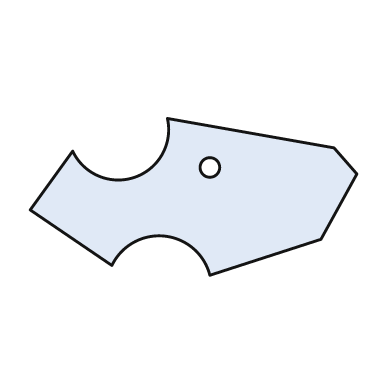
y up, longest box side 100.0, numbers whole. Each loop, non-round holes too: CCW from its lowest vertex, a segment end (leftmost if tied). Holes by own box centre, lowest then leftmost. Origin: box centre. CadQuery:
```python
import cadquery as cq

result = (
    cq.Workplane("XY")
    .moveTo(5.0, -24.0)
    .lineTo(39.0, -13.0)
    .lineTo(50.0, 7.0)
    .lineTo(43.0, 15.0)
    .lineTo(-8.0, 24.0)
    .threePointArc((-18.0, 6.0), (-37.0, 14.0))
    .lineTo(-50.0, -4.0)
    .lineTo(-25.0, -21.0)
    .threePointArc((-9.0, -12.0), (5.0, -24.0))
    .close()
    .moveTo(5.0, 9.0)
    .circle(3.0)
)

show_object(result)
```